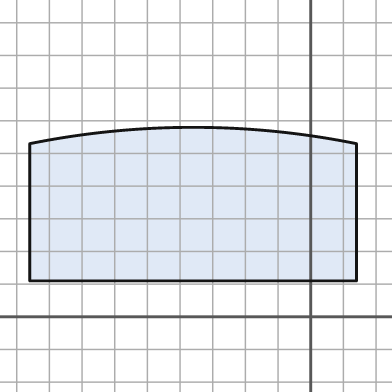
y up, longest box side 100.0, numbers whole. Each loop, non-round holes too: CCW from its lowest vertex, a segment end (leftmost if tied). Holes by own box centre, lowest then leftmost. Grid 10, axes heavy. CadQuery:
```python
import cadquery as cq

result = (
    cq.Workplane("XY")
    .moveTo(-86.0, 11.0)
    .lineTo(14.0, 11.0)
    .lineTo(14.0, 53.0)
    .threePointArc((-36.0, 58.0), (-86.0, 53.0))
    .close()
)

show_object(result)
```